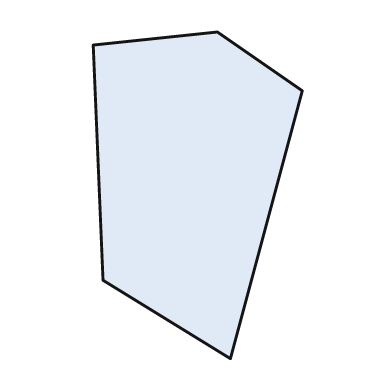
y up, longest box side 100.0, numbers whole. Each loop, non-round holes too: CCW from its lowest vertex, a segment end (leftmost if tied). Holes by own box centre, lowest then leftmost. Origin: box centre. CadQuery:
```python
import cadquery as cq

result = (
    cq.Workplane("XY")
    .moveTo(10.0, -50.0)
    .lineTo(32.0, 32.0)
    .lineTo(6.0, 50.0)
    .lineTo(-32.0, 46.0)
    .lineTo(-29.0, -26.0)
    .close()
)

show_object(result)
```